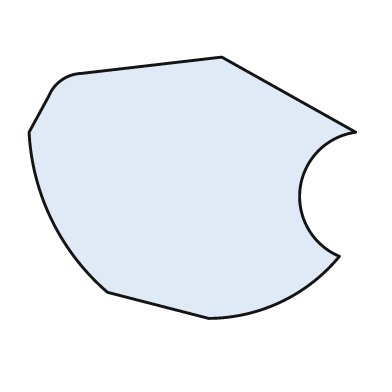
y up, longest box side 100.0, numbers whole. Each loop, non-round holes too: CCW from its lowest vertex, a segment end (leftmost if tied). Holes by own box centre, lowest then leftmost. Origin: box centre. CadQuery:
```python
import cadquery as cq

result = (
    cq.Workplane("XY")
    .moveTo(5.0, -40.0)
    .threePointArc((27.0, -35.0), (45.0, -21.0))
    .threePointArc((33.0, 0.0), (50.0, 17.0))
    .lineTo(9.0, 40.0)
    .lineTo(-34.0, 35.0)
    .threePointArc((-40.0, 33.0), (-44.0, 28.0))
    .lineTo(-50.0, 17.0)
    .threePointArc((-43.0, -10.0), (-26.0, -32.0))
    .close()
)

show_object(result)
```